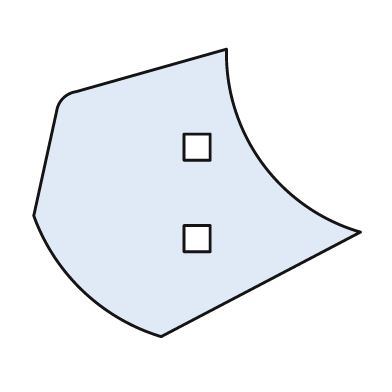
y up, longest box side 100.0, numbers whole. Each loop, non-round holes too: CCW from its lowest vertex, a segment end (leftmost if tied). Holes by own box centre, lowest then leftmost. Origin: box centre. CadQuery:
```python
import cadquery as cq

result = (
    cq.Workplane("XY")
    .moveTo(-11.0, -44.0)
    .lineTo(50.0, -12.0)
    .threePointArc((20.0, 9.0), (9.0, 44.0))
    .lineTo(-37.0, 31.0)
    .threePointArc((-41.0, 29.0), (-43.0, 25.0))
    .lineTo(-50.0, -7.0)
    .threePointArc((-35.0, -30.0), (-11.0, -44.0))
    .close()
    .moveTo(-4.0, -18.0)
    .lineTo(4.0, -18.0)
    .lineTo(4.0, -10.0)
    .lineTo(-4.0, -10.0)
    .close()
    .moveTo(-4.0, 10.0)
    .lineTo(4.0, 10.0)
    .lineTo(4.0, 18.0)
    .lineTo(-4.0, 18.0)
    .close()
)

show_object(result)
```